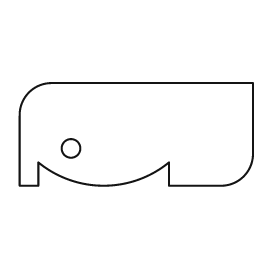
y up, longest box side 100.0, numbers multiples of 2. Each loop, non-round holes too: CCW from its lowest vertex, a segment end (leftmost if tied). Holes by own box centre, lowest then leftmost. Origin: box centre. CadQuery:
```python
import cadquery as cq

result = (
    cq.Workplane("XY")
    .moveTo(-50.0, -22.0)
    .lineTo(-42.0, -22.0)
    .lineTo(-42.0, -12.0)
    .threePointArc((-14.0, -22.0), (14.0, -12.0))
    .lineTo(14.0, -22.0)
    .lineTo(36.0, -22.0)
    .threePointArc((46.0, -18.0), (50.0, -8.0))
    .lineTo(50.0, 22.0)
    .lineTo(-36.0, 22.0)
    .threePointArc((-46.0, 18.0), (-50.0, 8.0))
    .close()
    .moveTo(-28.0, -6.0)
    .circle(4.0)
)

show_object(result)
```